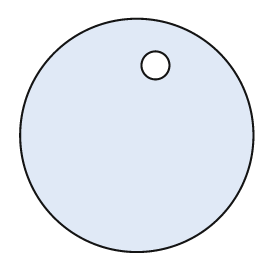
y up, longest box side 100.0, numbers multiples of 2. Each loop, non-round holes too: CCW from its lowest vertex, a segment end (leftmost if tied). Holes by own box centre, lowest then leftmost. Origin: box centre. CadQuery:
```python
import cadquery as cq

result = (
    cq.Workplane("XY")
    .moveTo(0.0, 0.0)
    .circle(50.0)
    .moveTo(8.0, 30.0)
    .circle(6.0)
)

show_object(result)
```